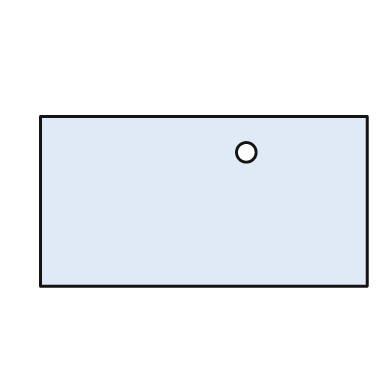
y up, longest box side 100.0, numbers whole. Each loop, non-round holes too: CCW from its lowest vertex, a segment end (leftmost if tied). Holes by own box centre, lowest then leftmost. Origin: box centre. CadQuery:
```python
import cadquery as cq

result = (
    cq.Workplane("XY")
    .moveTo(-50.0, -26.0)
    .lineTo(50.0, -26.0)
    .lineTo(50.0, 26.0)
    .lineTo(-50.0, 26.0)
    .close()
    .moveTo(13.0, 15.0)
    .circle(3.0)
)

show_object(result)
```